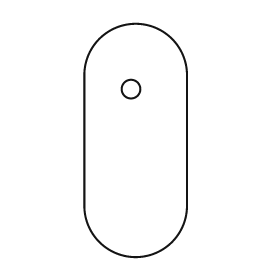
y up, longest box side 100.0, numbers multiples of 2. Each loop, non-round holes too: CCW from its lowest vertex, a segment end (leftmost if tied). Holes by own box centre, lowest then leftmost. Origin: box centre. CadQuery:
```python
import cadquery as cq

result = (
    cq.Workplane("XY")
    .moveTo(-22.0, -28.0)
    .threePointArc((0.0, -50.0), (22.0, -28.0))
    .lineTo(22.0, 28.0)
    .threePointArc((0.0, 50.0), (-22.0, 28.0))
    .close()
    .moveTo(-2.0, 22.0)
    .circle(4.0)
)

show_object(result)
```